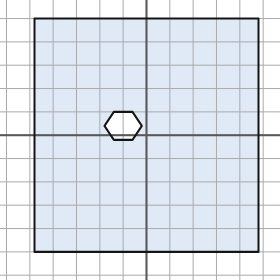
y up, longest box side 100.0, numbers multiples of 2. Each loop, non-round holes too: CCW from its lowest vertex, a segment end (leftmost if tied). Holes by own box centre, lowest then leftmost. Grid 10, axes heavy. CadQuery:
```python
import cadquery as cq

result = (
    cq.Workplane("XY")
    .moveTo(-48.0, -50.0)
    .lineTo(48.0, -50.0)
    .lineTo(48.0, 50.0)
    .lineTo(-48.0, 50.0)
    .close()
    .moveTo(-14.0, -2.0)
    .lineTo(-6.0, -2.0)
    .lineTo(-2.0, 4.0)
    .lineTo(-6.0, 10.0)
    .lineTo(-14.0, 10.0)
    .lineTo(-18.0, 4.0)
    .close()
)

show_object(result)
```